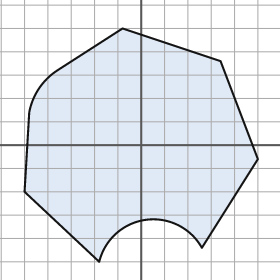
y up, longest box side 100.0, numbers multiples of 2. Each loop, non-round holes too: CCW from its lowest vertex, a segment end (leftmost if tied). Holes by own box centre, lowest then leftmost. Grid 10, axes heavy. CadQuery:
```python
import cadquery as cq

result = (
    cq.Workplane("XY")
    .moveTo(-18.0, -50.0)
    .threePointArc((2.0, -32.0), (26.0, -44.0))
    .lineTo(50.0, -6.0)
    .lineTo(34.0, 36.0)
    .lineTo(-8.0, 50.0)
    .lineTo(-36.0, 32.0)
    .threePointArc((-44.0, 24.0), (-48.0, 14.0))
    .lineTo(-50.0, -20.0)
    .close()
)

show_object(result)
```